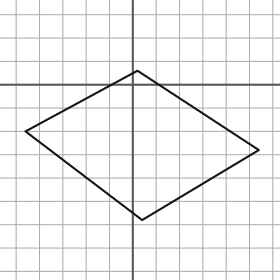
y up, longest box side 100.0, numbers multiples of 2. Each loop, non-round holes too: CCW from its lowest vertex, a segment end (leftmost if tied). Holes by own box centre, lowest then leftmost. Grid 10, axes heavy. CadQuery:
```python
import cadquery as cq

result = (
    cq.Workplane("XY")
    .moveTo(4.0, -58.0)
    .lineTo(54.0, -28.0)
    .lineTo(2.0, 6.0)
    .lineTo(-46.0, -20.0)
    .close()
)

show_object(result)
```